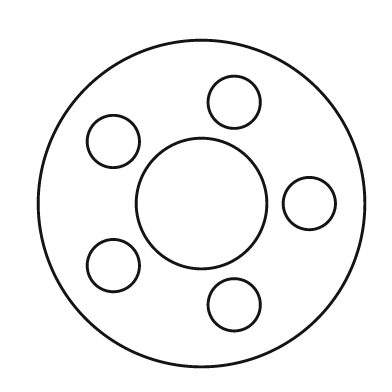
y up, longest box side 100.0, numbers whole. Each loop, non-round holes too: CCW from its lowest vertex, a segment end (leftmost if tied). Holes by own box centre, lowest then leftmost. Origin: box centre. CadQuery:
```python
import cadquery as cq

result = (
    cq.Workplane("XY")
    .moveTo(0.0, 0.0)
    .circle(50.0)
    .moveTo(10.0, -31.0)
    .circle(8.0)
    .moveTo(-27.0, -19.0)
    .circle(8.0)
    .moveTo(0.0, 0.0)
    .circle(20.0)
    .moveTo(33.0, 0.0)
    .circle(8.0)
    .moveTo(-27.0, 19.0)
    .circle(8.0)
    .moveTo(10.0, 31.0)
    .circle(8.0)
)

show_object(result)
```